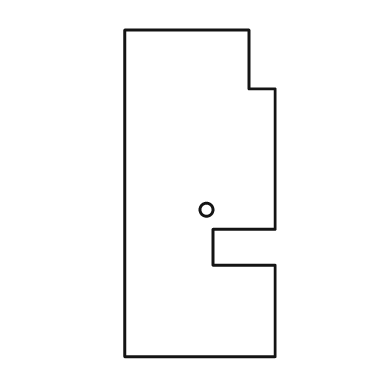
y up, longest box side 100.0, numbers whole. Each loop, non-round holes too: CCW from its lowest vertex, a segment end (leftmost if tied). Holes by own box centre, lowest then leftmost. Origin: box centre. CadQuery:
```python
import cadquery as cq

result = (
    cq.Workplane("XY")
    .moveTo(-23.0, -50.0)
    .lineTo(23.0, -50.0)
    .lineTo(23.0, -22.0)
    .lineTo(4.0, -22.0)
    .lineTo(4.0, -11.0)
    .lineTo(23.0, -11.0)
    .lineTo(23.0, 32.0)
    .lineTo(15.0, 32.0)
    .lineTo(15.0, 50.0)
    .lineTo(-23.0, 50.0)
    .close()
    .moveTo(2.0, -5.0)
    .circle(2.0)
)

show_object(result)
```